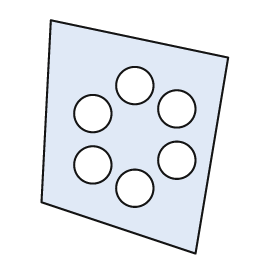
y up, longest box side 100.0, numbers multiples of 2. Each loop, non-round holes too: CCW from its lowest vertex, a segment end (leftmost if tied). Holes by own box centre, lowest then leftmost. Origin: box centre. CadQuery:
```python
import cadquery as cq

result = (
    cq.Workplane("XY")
    .moveTo(26.0, -50.0)
    .lineTo(40.0, 34.0)
    .lineTo(-36.0, 50.0)
    .lineTo(-40.0, -28.0)
    .close()
    .moveTo(0.0, -22.0)
    .circle(8.0)
    .moveTo(-18.0, -12.0)
    .circle(8.0)
    .moveTo(18.0, -10.0)
    .circle(8.0)
    .moveTo(-18.0, 10.0)
    .circle(8.0)
    .moveTo(18.0, 12.0)
    .circle(8.0)
    .moveTo(0.0, 22.0)
    .circle(8.0)
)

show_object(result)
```